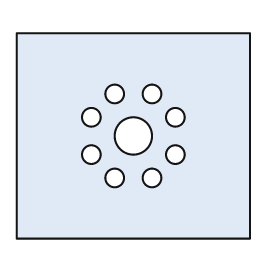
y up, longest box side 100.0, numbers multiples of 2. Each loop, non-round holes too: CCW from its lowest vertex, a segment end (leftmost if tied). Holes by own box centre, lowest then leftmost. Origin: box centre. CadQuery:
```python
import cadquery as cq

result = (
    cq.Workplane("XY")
    .moveTo(-50.0, -44.0)
    .lineTo(50.0, -44.0)
    .lineTo(50.0, 44.0)
    .lineTo(-50.0, 44.0)
    .close()
    .moveTo(-8.0, -18.0)
    .circle(4.0)
    .moveTo(8.0, -18.0)
    .circle(4.0)
    .moveTo(-18.0, -8.0)
    .circle(4.0)
    .moveTo(18.0, -8.0)
    .circle(4.0)
    .moveTo(0.0, 0.0)
    .circle(8.0)
    .moveTo(-18.0, 8.0)
    .circle(4.0)
    .moveTo(18.0, 8.0)
    .circle(4.0)
    .moveTo(-8.0, 18.0)
    .circle(4.0)
    .moveTo(8.0, 18.0)
    .circle(4.0)
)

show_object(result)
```